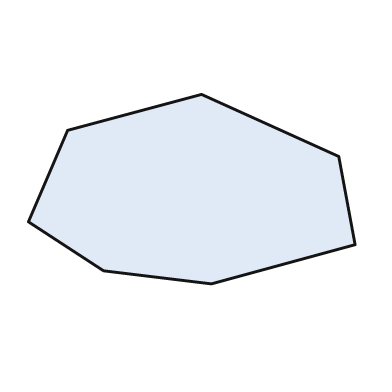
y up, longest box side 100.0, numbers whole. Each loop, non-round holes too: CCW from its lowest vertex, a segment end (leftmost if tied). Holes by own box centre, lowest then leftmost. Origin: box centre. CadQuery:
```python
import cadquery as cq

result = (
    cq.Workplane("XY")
    .moveTo(6.0, -29.0)
    .lineTo(50.0, -17.0)
    .lineTo(45.0, 10.0)
    .lineTo(3.0, 29.0)
    .lineTo(-38.0, 18.0)
    .lineTo(-50.0, -10.0)
    .lineTo(-27.0, -25.0)
    .close()
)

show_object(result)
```